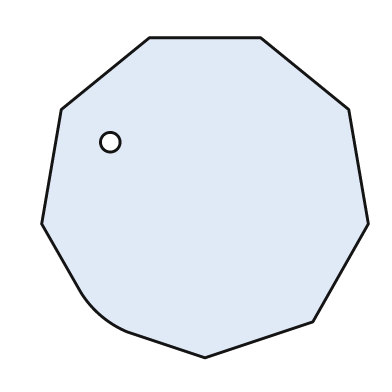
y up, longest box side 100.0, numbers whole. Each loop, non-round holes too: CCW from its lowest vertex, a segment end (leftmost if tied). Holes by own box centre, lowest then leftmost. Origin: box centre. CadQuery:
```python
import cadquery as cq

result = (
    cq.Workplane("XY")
    .moveTo(0.0, -49.0)
    .lineTo(33.0, -38.0)
    .lineTo(50.0, -8.0)
    .lineTo(44.0, 27.0)
    .lineTo(17.0, 49.0)
    .lineTo(-17.0, 49.0)
    .lineTo(-44.0, 27.0)
    .lineTo(-50.0, -8.0)
    .lineTo(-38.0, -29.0)
    .threePointArc((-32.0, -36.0), (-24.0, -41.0))
    .close()
    .moveTo(-29.0, 17.0)
    .circle(3.0)
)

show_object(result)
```